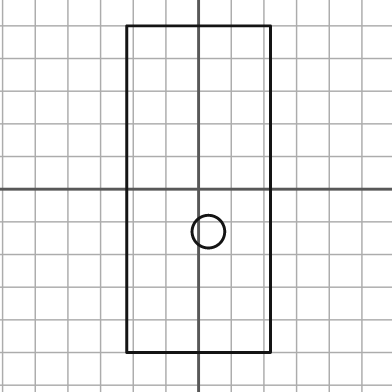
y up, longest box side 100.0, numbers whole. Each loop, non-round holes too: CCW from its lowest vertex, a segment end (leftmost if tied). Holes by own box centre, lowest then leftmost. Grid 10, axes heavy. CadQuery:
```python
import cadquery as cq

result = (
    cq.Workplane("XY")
    .moveTo(-22.0, -50.0)
    .lineTo(22.0, -50.0)
    .lineTo(22.0, 50.0)
    .lineTo(-22.0, 50.0)
    .close()
    .moveTo(3.0, -13.0)
    .circle(5.0)
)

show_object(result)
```